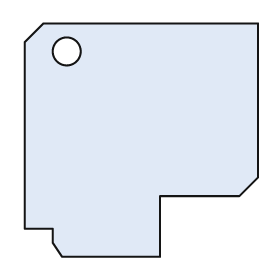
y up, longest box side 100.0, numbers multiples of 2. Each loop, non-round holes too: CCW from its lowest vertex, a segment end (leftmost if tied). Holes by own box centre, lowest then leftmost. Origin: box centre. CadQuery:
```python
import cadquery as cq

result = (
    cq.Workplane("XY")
    .moveTo(-34.0, -50.0)
    .lineTo(8.0, -50.0)
    .lineTo(8.0, -24.0)
    .lineTo(42.0, -24.0)
    .lineTo(50.0, -16.0)
    .lineTo(50.0, 50.0)
    .lineTo(-42.0, 50.0)
    .lineTo(-50.0, 42.0)
    .lineTo(-50.0, -38.0)
    .lineTo(-38.0, -38.0)
    .lineTo(-38.0, -44.0)
    .close()
    .moveTo(-32.0, 38.0)
    .circle(6.0)
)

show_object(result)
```